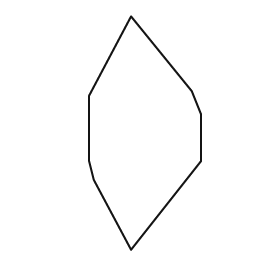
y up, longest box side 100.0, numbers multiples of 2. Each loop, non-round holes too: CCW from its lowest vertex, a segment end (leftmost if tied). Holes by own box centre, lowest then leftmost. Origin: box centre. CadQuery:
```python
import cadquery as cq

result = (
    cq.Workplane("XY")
    .moveTo(-6.0, -50.0)
    .lineTo(24.0, -12.0)
    .lineTo(24.0, 8.0)
    .lineTo(20.0, 18.0)
    .lineTo(-6.0, 50.0)
    .lineTo(-24.0, 16.0)
    .lineTo(-24.0, -12.0)
    .lineTo(-22.0, -20.0)
    .close()
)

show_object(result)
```